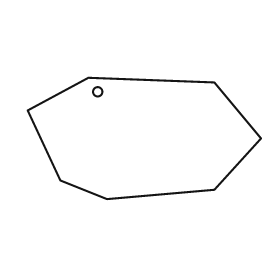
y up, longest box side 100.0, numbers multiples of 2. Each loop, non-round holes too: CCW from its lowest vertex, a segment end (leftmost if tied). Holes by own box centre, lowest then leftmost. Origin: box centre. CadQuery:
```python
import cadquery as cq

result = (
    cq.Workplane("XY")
    .moveTo(-16.0, -26.0)
    .lineTo(30.0, -22.0)
    .lineTo(50.0, 0.0)
    .lineTo(30.0, 24.0)
    .lineTo(-24.0, 26.0)
    .lineTo(-50.0, 12.0)
    .lineTo(-36.0, -18.0)
    .close()
    .moveTo(-20.0, 20.0)
    .circle(2.0)
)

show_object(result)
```